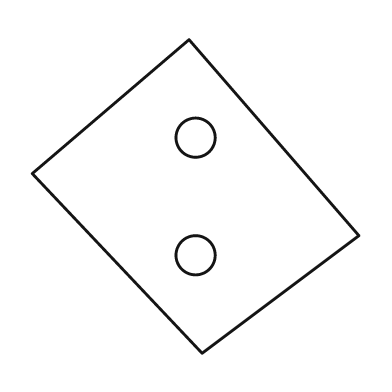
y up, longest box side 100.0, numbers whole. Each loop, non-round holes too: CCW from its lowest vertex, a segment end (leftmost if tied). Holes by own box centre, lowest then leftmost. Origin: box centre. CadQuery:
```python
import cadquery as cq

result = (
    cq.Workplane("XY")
    .moveTo(2.0, -48.0)
    .lineTo(50.0, -12.0)
    .lineTo(-2.0, 48.0)
    .lineTo(-50.0, 7.0)
    .close()
    .moveTo(0.0, -18.0)
    .circle(6.0)
    .moveTo(0.0, 18.0)
    .circle(6.0)
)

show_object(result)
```